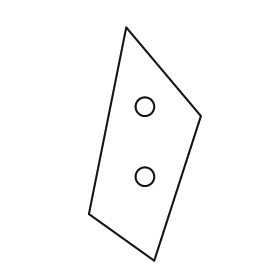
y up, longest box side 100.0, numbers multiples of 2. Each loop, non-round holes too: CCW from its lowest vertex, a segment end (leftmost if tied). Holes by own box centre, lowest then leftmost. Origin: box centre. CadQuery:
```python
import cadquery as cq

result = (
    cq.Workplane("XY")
    .moveTo(4.0, -50.0)
    .lineTo(24.0, 12.0)
    .lineTo(-8.0, 50.0)
    .lineTo(-24.0, -30.0)
    .close()
    .moveTo(0.0, -14.0)
    .circle(4.0)
    .moveTo(0.0, 16.0)
    .circle(4.0)
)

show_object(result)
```